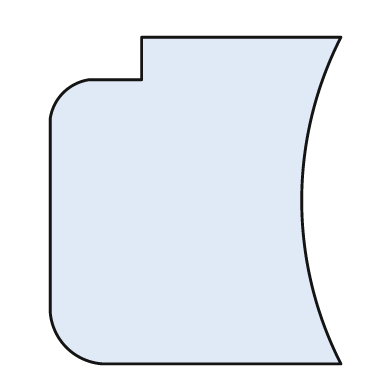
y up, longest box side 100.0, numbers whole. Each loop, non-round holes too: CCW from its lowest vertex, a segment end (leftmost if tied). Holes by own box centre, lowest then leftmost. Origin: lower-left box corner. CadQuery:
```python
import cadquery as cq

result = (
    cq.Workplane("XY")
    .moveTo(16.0, 0.0)
    .lineTo(89.0, 0.0)
    .threePointArc((77.0, 50.0), (89.0, 100.0))
    .lineTo(28.0, 100.0)
    .lineTo(28.0, 87.0)
    .lineTo(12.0, 87.0)
    .threePointArc((4.0, 83.0), (0.0, 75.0))
    .lineTo(0.0, 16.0)
    .threePointArc((5.0, 5.0), (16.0, 0.0))
    .close()
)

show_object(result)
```